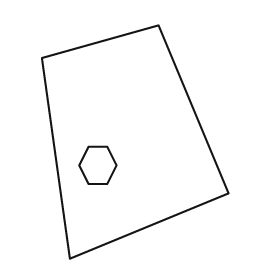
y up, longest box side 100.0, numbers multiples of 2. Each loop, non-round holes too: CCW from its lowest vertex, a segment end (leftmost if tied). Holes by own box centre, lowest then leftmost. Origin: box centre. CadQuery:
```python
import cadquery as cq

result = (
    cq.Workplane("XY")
    .moveTo(-28.0, -50.0)
    .lineTo(40.0, -22.0)
    .lineTo(10.0, 50.0)
    .lineTo(-40.0, 36.0)
    .close()
    .moveTo(-20.0, -18.0)
    .lineTo(-12.0, -18.0)
    .lineTo(-8.0, -10.0)
    .lineTo(-12.0, -2.0)
    .lineTo(-20.0, -2.0)
    .lineTo(-24.0, -10.0)
    .close()
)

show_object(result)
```